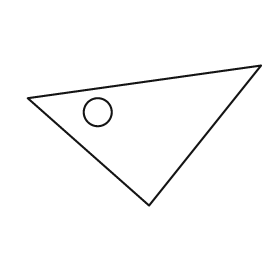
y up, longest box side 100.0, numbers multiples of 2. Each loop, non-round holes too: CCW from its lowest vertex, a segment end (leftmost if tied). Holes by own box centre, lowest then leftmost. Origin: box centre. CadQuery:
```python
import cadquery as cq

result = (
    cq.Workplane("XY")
    .moveTo(2.0, -30.0)
    .lineTo(50.0, 30.0)
    .lineTo(-50.0, 16.0)
    .close()
    .moveTo(-20.0, 10.0)
    .circle(6.0)
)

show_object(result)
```